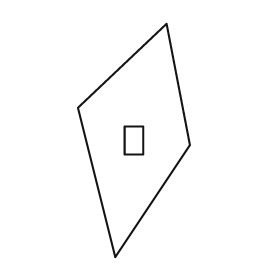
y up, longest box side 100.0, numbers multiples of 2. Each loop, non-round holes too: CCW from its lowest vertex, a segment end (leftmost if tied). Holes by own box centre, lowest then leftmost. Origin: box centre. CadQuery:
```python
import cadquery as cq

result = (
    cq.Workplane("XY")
    .moveTo(-8.0, -50.0)
    .lineTo(24.0, -2.0)
    .lineTo(14.0, 50.0)
    .lineTo(-24.0, 14.0)
    .close()
    .moveTo(-4.0, -6.0)
    .lineTo(4.0, -6.0)
    .lineTo(4.0, 6.0)
    .lineTo(-4.0, 6.0)
    .close()
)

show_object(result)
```